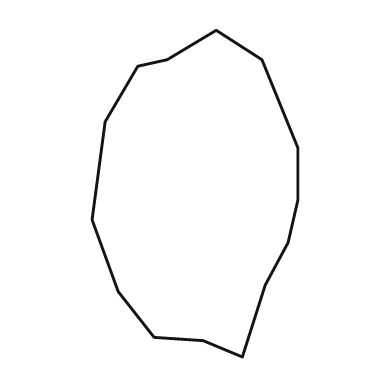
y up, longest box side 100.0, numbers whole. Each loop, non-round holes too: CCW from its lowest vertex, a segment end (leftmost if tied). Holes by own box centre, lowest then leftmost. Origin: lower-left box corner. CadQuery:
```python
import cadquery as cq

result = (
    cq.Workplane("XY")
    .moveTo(46.0, 0.0)
    .lineTo(53.0, 22.0)
    .lineTo(60.0, 35.0)
    .lineTo(63.0, 48.0)
    .lineTo(63.0, 64.0)
    .lineTo(52.0, 91.0)
    .lineTo(38.0, 100.0)
    .lineTo(23.0, 91.0)
    .lineTo(14.0, 89.0)
    .lineTo(4.0, 72.0)
    .lineTo(0.0, 42.0)
    .lineTo(8.0, 20.0)
    .lineTo(19.0, 6.0)
    .lineTo(34.0, 5.0)
    .close()
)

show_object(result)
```